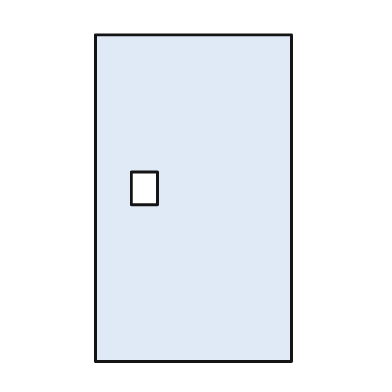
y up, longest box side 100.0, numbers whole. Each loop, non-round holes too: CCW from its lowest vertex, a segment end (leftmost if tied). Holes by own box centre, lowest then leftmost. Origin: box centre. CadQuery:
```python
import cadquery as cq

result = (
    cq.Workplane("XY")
    .moveTo(-30.0, -50.0)
    .lineTo(30.0, -50.0)
    .lineTo(30.0, 50.0)
    .lineTo(-30.0, 50.0)
    .close()
    .moveTo(-19.0, -2.0)
    .lineTo(-11.0, -2.0)
    .lineTo(-11.0, 8.0)
    .lineTo(-19.0, 8.0)
    .close()
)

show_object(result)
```